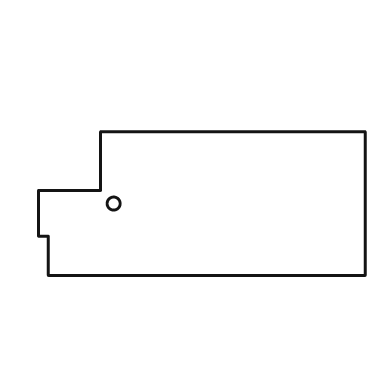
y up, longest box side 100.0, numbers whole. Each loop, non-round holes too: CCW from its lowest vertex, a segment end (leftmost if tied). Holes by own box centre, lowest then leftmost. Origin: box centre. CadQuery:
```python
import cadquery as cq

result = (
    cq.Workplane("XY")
    .moveTo(-47.0, -22.0)
    .lineTo(50.0, -22.0)
    .lineTo(50.0, 22.0)
    .lineTo(-31.0, 22.0)
    .lineTo(-31.0, 4.0)
    .lineTo(-50.0, 4.0)
    .lineTo(-50.0, -10.0)
    .lineTo(-47.0, -10.0)
    .close()
    .moveTo(-27.0, 0.0)
    .circle(2.0)
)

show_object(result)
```